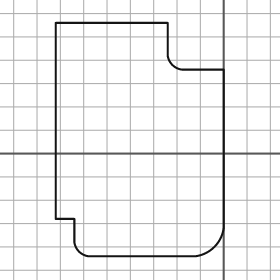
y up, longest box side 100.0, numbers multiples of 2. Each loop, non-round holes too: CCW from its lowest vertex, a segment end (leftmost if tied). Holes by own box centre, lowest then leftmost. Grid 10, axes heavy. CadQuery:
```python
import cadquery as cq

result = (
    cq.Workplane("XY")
    .moveTo(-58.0, -44.0)
    .lineTo(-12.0, -44.0)
    .threePointArc((-4.0, -40.0), (0.0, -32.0))
    .lineTo(0.0, 36.0)
    .lineTo(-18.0, 36.0)
    .threePointArc((-22.0, 38.0), (-24.0, 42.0))
    .lineTo(-24.0, 56.0)
    .lineTo(-72.0, 56.0)
    .lineTo(-72.0, -28.0)
    .lineTo(-64.0, -28.0)
    .lineTo(-64.0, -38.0)
    .threePointArc((-62.0, -42.0), (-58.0, -44.0))
    .close()
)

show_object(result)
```